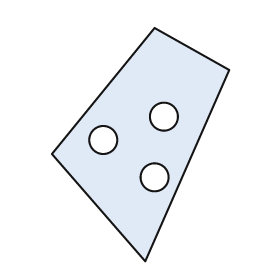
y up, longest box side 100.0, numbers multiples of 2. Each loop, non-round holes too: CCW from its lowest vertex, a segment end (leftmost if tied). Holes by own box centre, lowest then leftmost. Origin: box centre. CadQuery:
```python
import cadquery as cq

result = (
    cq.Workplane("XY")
    .moveTo(2.0, -50.0)
    .lineTo(38.0, 32.0)
    .lineTo(6.0, 50.0)
    .lineTo(-38.0, -4.0)
    .close()
    .moveTo(6.0, -14.0)
    .circle(6.0)
    .moveTo(-16.0, 2.0)
    .circle(6.0)
    .moveTo(10.0, 12.0)
    .circle(6.0)
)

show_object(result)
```